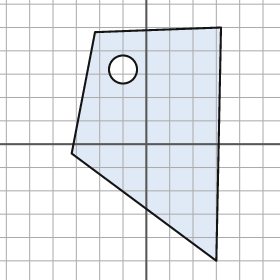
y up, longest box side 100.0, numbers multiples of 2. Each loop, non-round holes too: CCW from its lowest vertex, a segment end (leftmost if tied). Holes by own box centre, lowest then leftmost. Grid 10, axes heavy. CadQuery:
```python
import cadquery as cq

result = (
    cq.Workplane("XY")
    .moveTo(30.0, -50.0)
    .lineTo(32.0, 50.0)
    .lineTo(-22.0, 48.0)
    .lineTo(-32.0, -4.0)
    .close()
    .moveTo(-10.0, 32.0)
    .circle(6.0)
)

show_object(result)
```